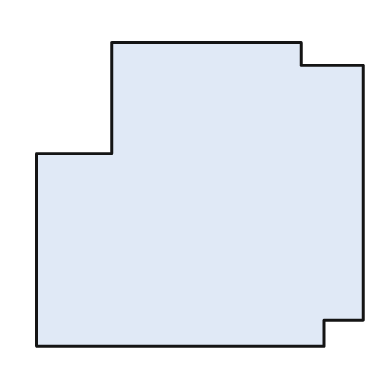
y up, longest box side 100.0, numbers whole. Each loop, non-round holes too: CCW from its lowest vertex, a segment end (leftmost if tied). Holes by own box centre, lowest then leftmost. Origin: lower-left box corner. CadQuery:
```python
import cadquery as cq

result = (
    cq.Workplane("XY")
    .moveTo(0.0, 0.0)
    .lineTo(88.0, 0.0)
    .lineTo(88.0, 8.0)
    .lineTo(100.0, 8.0)
    .lineTo(100.0, 86.0)
    .lineTo(81.0, 86.0)
    .lineTo(81.0, 93.0)
    .lineTo(23.0, 93.0)
    .lineTo(23.0, 59.0)
    .lineTo(0.0, 59.0)
    .close()
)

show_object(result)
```